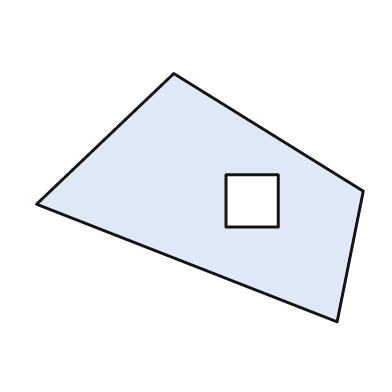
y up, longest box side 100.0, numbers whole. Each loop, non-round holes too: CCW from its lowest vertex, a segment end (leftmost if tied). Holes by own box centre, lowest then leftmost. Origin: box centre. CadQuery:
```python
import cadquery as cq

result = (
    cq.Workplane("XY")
    .moveTo(42.0, -38.0)
    .lineTo(50.0, 2.0)
    .lineTo(-8.0, 38.0)
    .lineTo(-50.0, -2.0)
    .close()
    .moveTo(8.0, -9.0)
    .lineTo(24.0, -9.0)
    .lineTo(24.0, 7.0)
    .lineTo(8.0, 7.0)
    .close()
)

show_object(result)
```